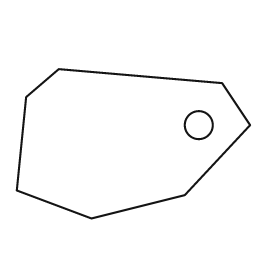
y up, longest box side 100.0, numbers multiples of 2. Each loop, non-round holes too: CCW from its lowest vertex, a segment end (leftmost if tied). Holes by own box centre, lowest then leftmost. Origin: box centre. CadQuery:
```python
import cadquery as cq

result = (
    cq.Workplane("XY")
    .moveTo(-18.0, -32.0)
    .lineTo(22.0, -22.0)
    .lineTo(50.0, 8.0)
    .lineTo(38.0, 26.0)
    .lineTo(-32.0, 32.0)
    .lineTo(-46.0, 20.0)
    .lineTo(-50.0, -20.0)
    .close()
    .moveTo(28.0, 8.0)
    .circle(6.0)
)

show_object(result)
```